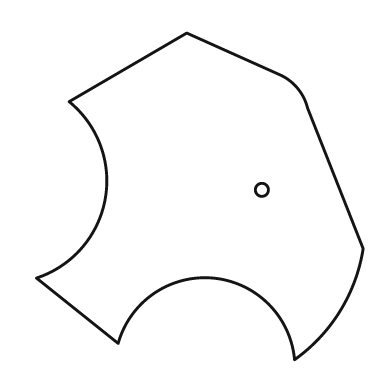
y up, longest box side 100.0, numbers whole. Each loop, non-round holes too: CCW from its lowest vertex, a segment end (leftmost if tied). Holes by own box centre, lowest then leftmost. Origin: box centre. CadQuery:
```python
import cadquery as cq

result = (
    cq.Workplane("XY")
    .moveTo(29.0, -50.0)
    .threePointArc((43.0, -35.0), (50.0, -16.0))
    .lineTo(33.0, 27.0)
    .threePointArc((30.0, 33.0), (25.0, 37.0))
    .lineTo(-4.0, 50.0)
    .lineTo(-40.0, 29.0)
    .threePointArc((-29.0, -1.0), (-50.0, -25.0))
    .lineTo(-25.0, -45.0)
    .threePointArc((4.0, -25.0), (29.0, -50.0))
    .close()
    .moveTo(19.0, 2.0)
    .circle(2.0)
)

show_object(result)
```